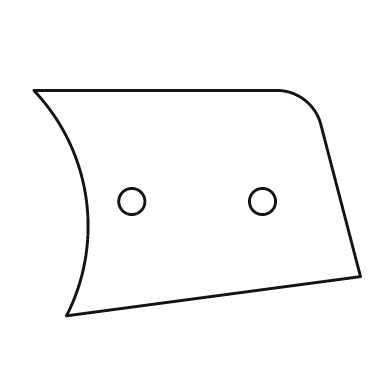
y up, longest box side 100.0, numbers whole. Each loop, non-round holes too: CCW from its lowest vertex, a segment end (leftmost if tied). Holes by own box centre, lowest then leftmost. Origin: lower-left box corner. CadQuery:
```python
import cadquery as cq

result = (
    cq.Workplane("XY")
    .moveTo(10.0, 0.0)
    .lineTo(100.0, 12.0)
    .lineTo(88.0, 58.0)
    .threePointArc((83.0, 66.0), (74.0, 69.0))
    .lineTo(0.0, 69.0)
    .threePointArc((16.0, 36.0), (10.0, 0.0))
    .close()
    .moveTo(30.0, 35.0)
    .circle(4.0)
    .moveTo(70.0, 35.0)
    .circle(4.0)
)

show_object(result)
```